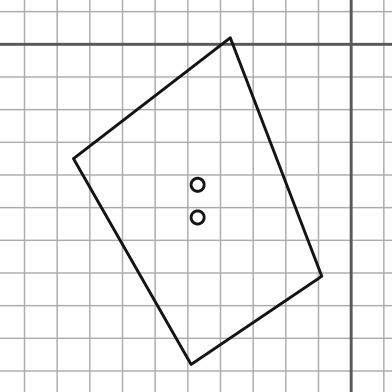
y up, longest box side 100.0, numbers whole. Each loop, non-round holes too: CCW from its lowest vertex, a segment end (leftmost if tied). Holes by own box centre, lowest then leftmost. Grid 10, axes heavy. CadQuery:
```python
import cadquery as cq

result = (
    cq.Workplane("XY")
    .moveTo(-49.0, -98.0)
    .lineTo(-9.0, -71.0)
    .lineTo(-37.0, 2.0)
    .lineTo(-85.0, -35.0)
    .close()
    .moveTo(-47.0, -53.0)
    .circle(2.0)
    .moveTo(-47.0, -43.0)
    .circle(2.0)
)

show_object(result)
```